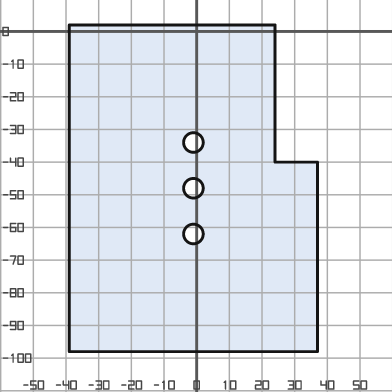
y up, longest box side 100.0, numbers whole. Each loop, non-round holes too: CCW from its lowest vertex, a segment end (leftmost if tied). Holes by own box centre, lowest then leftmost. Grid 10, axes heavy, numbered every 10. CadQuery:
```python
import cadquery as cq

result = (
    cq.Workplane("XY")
    .moveTo(-39.0, -98.0)
    .lineTo(37.0, -98.0)
    .lineTo(37.0, -40.0)
    .lineTo(24.0, -40.0)
    .lineTo(24.0, 2.0)
    .lineTo(-39.0, 2.0)
    .close()
    .moveTo(-1.0, -62.0)
    .circle(3.0)
    .moveTo(-1.0, -48.0)
    .circle(3.0)
    .moveTo(-1.0, -34.0)
    .circle(3.0)
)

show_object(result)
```